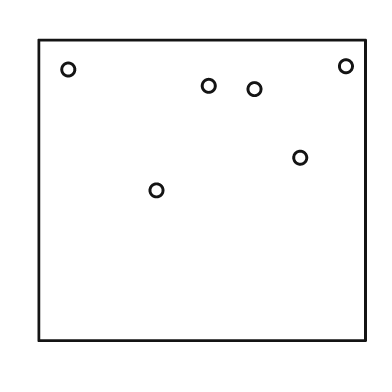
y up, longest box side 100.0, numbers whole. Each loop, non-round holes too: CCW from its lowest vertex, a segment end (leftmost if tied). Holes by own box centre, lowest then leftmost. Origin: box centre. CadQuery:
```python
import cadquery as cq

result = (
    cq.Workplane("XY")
    .moveTo(-50.0, -46.0)
    .lineTo(50.0, -46.0)
    .lineTo(50.0, 46.0)
    .lineTo(-50.0, 46.0)
    .close()
    .moveTo(-14.0, 0.0)
    .circle(2.0)
    .moveTo(30.0, 10.0)
    .circle(2.0)
    .moveTo(16.0, 31.0)
    .circle(2.0)
    .moveTo(2.0, 32.0)
    .circle(2.0)
    .moveTo(-41.0, 37.0)
    .circle(2.0)
    .moveTo(44.0, 38.0)
    .circle(2.0)
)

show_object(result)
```